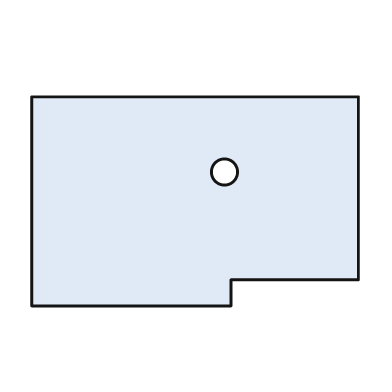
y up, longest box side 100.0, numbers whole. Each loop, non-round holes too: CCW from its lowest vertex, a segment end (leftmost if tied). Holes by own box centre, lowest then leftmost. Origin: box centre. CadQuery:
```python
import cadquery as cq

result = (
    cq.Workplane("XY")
    .moveTo(-50.0, -32.0)
    .lineTo(11.0, -32.0)
    .lineTo(11.0, -24.0)
    .lineTo(50.0, -24.0)
    .lineTo(50.0, 32.0)
    .lineTo(-50.0, 32.0)
    .close()
    .moveTo(9.0, 9.0)
    .circle(4.0)
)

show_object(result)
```